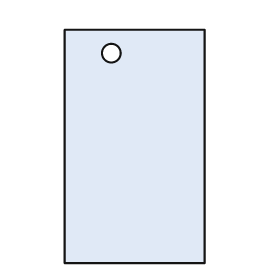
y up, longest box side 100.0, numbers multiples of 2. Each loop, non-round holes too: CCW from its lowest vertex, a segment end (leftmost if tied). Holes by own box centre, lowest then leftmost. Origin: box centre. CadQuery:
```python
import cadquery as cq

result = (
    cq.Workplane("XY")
    .moveTo(-30.0, -50.0)
    .lineTo(30.0, -50.0)
    .lineTo(30.0, 50.0)
    .lineTo(-30.0, 50.0)
    .close()
    .moveTo(-10.0, 40.0)
    .circle(4.0)
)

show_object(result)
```